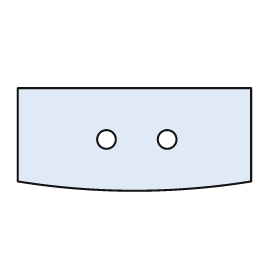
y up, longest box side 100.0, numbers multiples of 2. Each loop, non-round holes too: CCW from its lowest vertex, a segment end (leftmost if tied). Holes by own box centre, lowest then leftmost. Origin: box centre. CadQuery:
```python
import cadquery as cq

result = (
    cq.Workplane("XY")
    .moveTo(-50.0, -18.0)
    .threePointArc((0.0, -22.0), (50.0, -18.0))
    .lineTo(50.0, 22.0)
    .lineTo(-50.0, 22.0)
    .close()
    .moveTo(-12.0, 0.0)
    .circle(4.0)
    .moveTo(14.0, 0.0)
    .circle(4.0)
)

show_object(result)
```